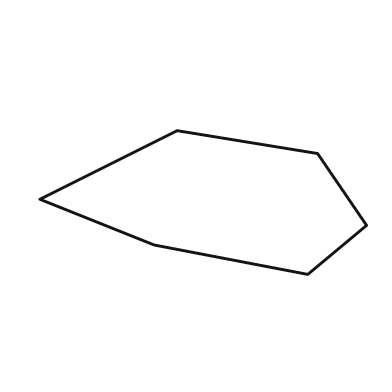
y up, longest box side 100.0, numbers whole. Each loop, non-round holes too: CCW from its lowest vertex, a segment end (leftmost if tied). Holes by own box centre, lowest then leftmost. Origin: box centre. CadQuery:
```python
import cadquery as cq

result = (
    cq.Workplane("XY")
    .moveTo(32.0, -22.0)
    .lineTo(50.0, -7.0)
    .lineTo(35.0, 15.0)
    .lineTo(-8.0, 22.0)
    .lineTo(-50.0, 1.0)
    .lineTo(-15.0, -13.0)
    .close()
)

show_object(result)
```